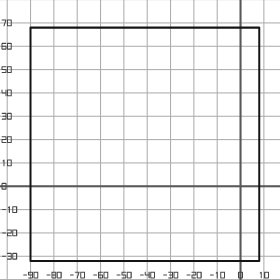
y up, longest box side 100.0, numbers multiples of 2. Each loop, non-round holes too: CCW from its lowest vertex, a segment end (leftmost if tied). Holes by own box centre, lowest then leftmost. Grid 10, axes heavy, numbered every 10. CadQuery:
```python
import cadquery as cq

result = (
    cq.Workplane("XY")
    .moveTo(-90.0, -32.0)
    .lineTo(8.0, -32.0)
    .lineTo(8.0, 68.0)
    .lineTo(-90.0, 68.0)
    .close()
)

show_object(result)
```